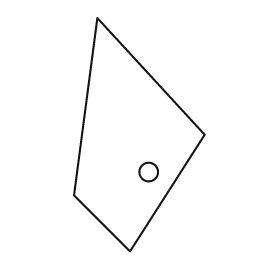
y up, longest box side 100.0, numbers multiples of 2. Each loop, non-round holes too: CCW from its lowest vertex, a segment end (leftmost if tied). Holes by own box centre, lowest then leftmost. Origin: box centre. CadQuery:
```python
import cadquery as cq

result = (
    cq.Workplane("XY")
    .moveTo(-4.0, -50.0)
    .lineTo(28.0, 0.0)
    .lineTo(-18.0, 50.0)
    .lineTo(-28.0, -26.0)
    .close()
    .moveTo(4.0, -16.0)
    .circle(4.0)
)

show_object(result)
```